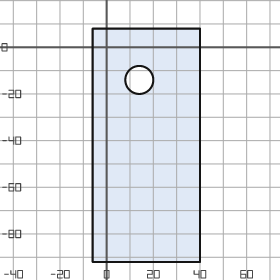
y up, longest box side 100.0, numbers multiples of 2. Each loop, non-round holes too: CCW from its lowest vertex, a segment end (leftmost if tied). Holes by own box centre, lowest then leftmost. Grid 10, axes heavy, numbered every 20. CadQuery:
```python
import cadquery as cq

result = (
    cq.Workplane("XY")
    .moveTo(-6.0, -92.0)
    .lineTo(40.0, -92.0)
    .lineTo(40.0, 8.0)
    .lineTo(-6.0, 8.0)
    .close()
    .moveTo(14.0, -14.0)
    .circle(6.0)
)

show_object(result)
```